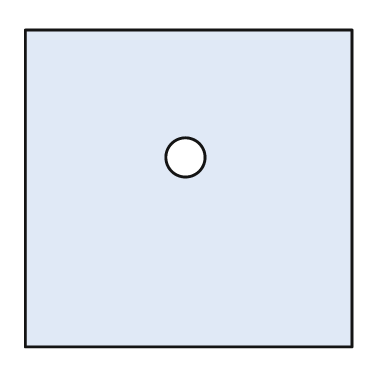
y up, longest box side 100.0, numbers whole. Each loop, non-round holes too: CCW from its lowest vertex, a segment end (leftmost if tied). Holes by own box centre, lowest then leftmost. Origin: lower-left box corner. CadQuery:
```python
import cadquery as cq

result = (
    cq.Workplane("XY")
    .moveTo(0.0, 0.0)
    .lineTo(100.0, 0.0)
    .lineTo(100.0, 97.0)
    .lineTo(0.0, 97.0)
    .close()
    .moveTo(49.0, 58.0)
    .circle(6.0)
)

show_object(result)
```